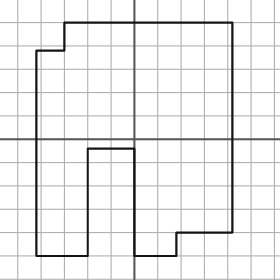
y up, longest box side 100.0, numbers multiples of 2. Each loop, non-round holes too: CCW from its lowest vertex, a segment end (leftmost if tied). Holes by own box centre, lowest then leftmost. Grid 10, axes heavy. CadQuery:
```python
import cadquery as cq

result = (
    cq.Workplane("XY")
    .moveTo(-42.0, -50.0)
    .lineTo(-20.0, -50.0)
    .lineTo(-20.0, -4.0)
    .lineTo(0.0, -4.0)
    .lineTo(0.0, -50.0)
    .lineTo(18.0, -50.0)
    .lineTo(18.0, -40.0)
    .lineTo(42.0, -40.0)
    .lineTo(42.0, 50.0)
    .lineTo(-30.0, 50.0)
    .lineTo(-30.0, 38.0)
    .lineTo(-42.0, 38.0)
    .close()
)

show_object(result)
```